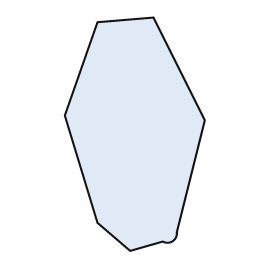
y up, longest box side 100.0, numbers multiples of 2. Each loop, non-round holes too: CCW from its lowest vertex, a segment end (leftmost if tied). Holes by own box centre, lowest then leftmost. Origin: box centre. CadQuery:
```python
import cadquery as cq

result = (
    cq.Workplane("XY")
    .moveTo(-2.0, -50.0)
    .lineTo(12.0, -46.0)
    .threePointArc((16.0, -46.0), (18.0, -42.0))
    .lineTo(30.0, 6.0)
    .lineTo(8.0, 50.0)
    .lineTo(-16.0, 48.0)
    .lineTo(-30.0, 8.0)
    .lineTo(-16.0, -38.0)
    .close()
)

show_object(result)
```